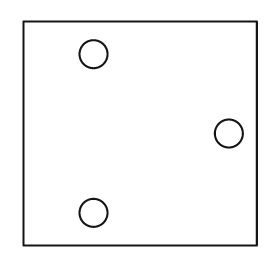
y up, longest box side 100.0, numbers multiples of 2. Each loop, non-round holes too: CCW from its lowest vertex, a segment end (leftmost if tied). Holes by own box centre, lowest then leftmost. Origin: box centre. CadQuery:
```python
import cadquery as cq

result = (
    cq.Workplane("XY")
    .moveTo(-50.0, -48.0)
    .lineTo(50.0, -48.0)
    .lineTo(50.0, 48.0)
    .lineTo(-50.0, 48.0)
    .close()
    .moveTo(-20.0, -34.0)
    .circle(6.0)
    .moveTo(38.0, 0.0)
    .circle(6.0)
    .moveTo(-20.0, 34.0)
    .circle(6.0)
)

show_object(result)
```